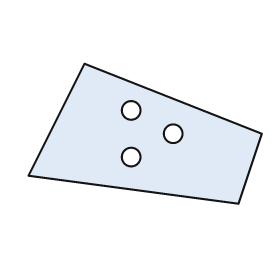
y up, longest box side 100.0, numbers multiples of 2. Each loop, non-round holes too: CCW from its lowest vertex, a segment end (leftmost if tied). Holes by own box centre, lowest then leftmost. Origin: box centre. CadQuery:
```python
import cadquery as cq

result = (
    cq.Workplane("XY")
    .moveTo(40.0, -30.0)
    .lineTo(50.0, 0.0)
    .lineTo(-26.0, 30.0)
    .lineTo(-50.0, -18.0)
    .close()
    .moveTo(-6.0, -10.0)
    .circle(4.0)
    .moveTo(12.0, 0.0)
    .circle(4.0)
    .moveTo(-6.0, 10.0)
    .circle(4.0)
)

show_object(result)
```